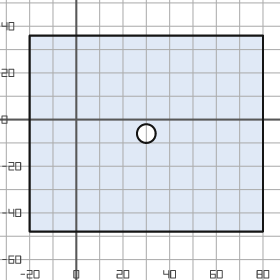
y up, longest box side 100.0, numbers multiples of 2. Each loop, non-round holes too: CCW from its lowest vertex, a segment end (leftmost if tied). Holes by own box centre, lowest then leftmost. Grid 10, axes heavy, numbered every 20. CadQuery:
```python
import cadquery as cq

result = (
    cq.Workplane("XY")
    .moveTo(-20.0, -48.0)
    .lineTo(80.0, -48.0)
    .lineTo(80.0, 36.0)
    .lineTo(-20.0, 36.0)
    .close()
    .moveTo(30.0, -6.0)
    .circle(4.0)
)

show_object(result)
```